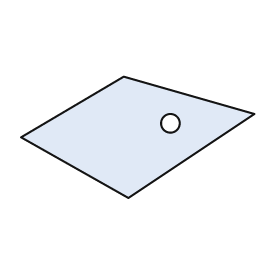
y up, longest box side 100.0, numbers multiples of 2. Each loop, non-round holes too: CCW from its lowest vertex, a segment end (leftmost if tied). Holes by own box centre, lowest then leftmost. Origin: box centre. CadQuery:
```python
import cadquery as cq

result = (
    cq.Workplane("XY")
    .moveTo(-4.0, -26.0)
    .lineTo(50.0, 10.0)
    .lineTo(-6.0, 26.0)
    .lineTo(-50.0, 0.0)
    .close()
    .moveTo(14.0, 6.0)
    .circle(4.0)
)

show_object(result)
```